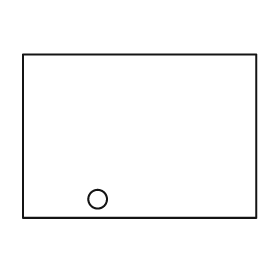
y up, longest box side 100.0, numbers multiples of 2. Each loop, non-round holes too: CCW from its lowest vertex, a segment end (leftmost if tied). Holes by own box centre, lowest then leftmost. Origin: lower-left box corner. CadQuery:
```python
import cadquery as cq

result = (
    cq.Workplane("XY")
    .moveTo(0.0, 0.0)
    .lineTo(100.0, 0.0)
    .lineTo(100.0, 70.0)
    .lineTo(0.0, 70.0)
    .close()
    .moveTo(32.0, 8.0)
    .circle(4.0)
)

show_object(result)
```